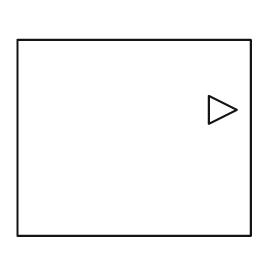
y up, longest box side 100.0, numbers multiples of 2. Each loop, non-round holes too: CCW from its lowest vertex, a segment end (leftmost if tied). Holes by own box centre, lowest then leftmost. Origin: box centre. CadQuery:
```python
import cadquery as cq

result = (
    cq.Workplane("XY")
    .moveTo(-50.0, -42.0)
    .lineTo(50.0, -42.0)
    .lineTo(50.0, 42.0)
    .lineTo(-50.0, 42.0)
    .close()
    .moveTo(32.0, 6.0)
    .lineTo(44.0, 12.0)
    .lineTo(32.0, 18.0)
    .close()
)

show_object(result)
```